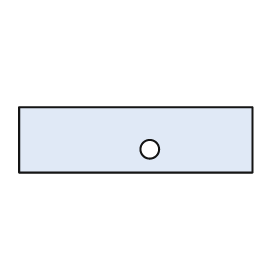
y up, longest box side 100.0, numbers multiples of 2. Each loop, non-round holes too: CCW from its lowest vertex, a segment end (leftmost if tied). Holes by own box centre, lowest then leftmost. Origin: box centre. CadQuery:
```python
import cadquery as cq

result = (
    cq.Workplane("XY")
    .moveTo(-50.0, -14.0)
    .lineTo(50.0, -14.0)
    .lineTo(50.0, 14.0)
    .lineTo(-50.0, 14.0)
    .close()
    .moveTo(6.0, -4.0)
    .circle(4.0)
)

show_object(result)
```